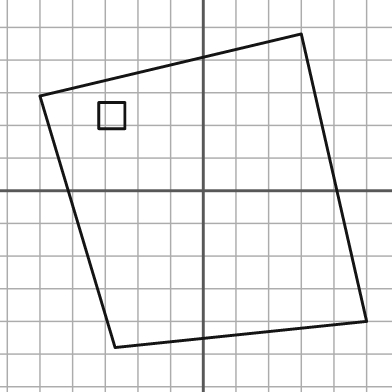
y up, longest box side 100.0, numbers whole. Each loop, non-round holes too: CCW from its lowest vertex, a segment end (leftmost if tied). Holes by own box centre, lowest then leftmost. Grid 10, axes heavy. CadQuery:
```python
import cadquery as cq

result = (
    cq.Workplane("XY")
    .moveTo(-27.0, -48.0)
    .lineTo(50.0, -40.0)
    .lineTo(30.0, 48.0)
    .lineTo(-50.0, 29.0)
    .close()
    .moveTo(-32.0, 19.0)
    .lineTo(-24.0, 19.0)
    .lineTo(-24.0, 27.0)
    .lineTo(-32.0, 27.0)
    .close()
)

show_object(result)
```